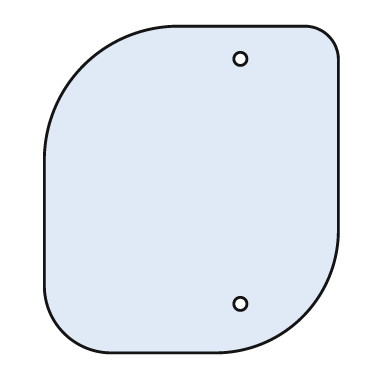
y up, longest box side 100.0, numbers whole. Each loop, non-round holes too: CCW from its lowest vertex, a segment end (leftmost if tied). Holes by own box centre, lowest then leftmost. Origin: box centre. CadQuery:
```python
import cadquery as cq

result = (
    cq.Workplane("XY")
    .moveTo(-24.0, -50.0)
    .lineTo(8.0, -50.0)
    .threePointArc((34.0, -39.0), (45.0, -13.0))
    .lineTo(45.0, 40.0)
    .threePointArc((42.0, 47.0), (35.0, 50.0))
    .lineTo(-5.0, 50.0)
    .threePointArc((-33.0, 38.0), (-45.0, 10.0))
    .lineTo(-45.0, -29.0)
    .threePointArc((-39.0, -44.0), (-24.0, -50.0))
    .close()
    .moveTo(15.0, -35.0)
    .circle(2.0)
    .moveTo(15.0, 40.0)
    .circle(2.0)
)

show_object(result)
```